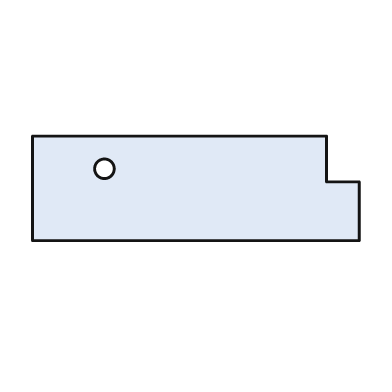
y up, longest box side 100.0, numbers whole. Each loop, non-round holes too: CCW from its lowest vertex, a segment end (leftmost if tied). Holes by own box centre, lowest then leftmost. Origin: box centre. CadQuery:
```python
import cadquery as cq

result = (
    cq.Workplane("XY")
    .moveTo(-50.0, -16.0)
    .lineTo(50.0, -16.0)
    .lineTo(50.0, 2.0)
    .lineTo(40.0, 2.0)
    .lineTo(40.0, 16.0)
    .lineTo(-50.0, 16.0)
    .close()
    .moveTo(-28.0, 6.0)
    .circle(3.0)
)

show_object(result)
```